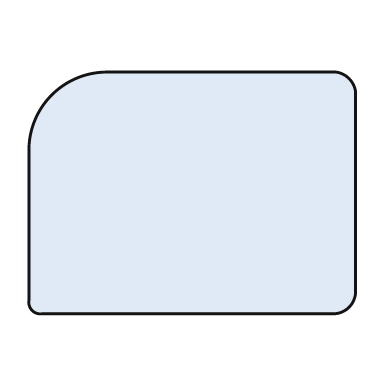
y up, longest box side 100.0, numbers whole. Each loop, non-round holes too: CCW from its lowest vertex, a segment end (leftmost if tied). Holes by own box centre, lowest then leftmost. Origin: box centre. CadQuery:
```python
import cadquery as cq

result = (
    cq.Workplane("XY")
    .moveTo(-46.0, -37.0)
    .lineTo(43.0, -37.0)
    .threePointArc((48.0, -35.0), (50.0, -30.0))
    .lineTo(50.0, 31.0)
    .threePointArc((48.0, 35.0), (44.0, 37.0))
    .lineTo(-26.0, 37.0)
    .threePointArc((-43.0, 30.0), (-50.0, 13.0))
    .lineTo(-50.0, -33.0)
    .threePointArc((-49.0, -36.0), (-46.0, -37.0))
    .close()
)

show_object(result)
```